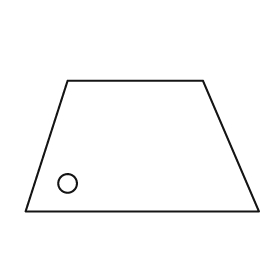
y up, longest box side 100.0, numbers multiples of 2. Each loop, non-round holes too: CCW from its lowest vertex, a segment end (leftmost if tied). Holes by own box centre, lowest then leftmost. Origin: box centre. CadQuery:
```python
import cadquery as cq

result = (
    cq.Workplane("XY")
    .moveTo(-50.0, -28.0)
    .lineTo(50.0, -28.0)
    .lineTo(26.0, 28.0)
    .lineTo(-32.0, 28.0)
    .close()
    .moveTo(-32.0, -16.0)
    .circle(4.0)
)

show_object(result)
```